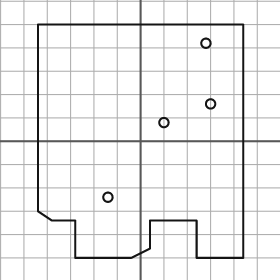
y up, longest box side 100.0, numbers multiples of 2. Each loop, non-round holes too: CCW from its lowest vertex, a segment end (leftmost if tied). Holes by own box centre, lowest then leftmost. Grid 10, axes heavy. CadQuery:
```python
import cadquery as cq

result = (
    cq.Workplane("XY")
    .moveTo(-28.0, -50.0)
    .lineTo(-4.0, -50.0)
    .lineTo(4.0, -46.0)
    .lineTo(4.0, -34.0)
    .lineTo(24.0, -34.0)
    .lineTo(24.0, -50.0)
    .lineTo(44.0, -50.0)
    .lineTo(44.0, 50.0)
    .lineTo(-44.0, 50.0)
    .lineTo(-44.0, -30.0)
    .lineTo(-38.0, -34.0)
    .lineTo(-28.0, -34.0)
    .close()
    .moveTo(-14.0, -24.0)
    .circle(2.0)
    .moveTo(10.0, 8.0)
    .circle(2.0)
    .moveTo(30.0, 16.0)
    .circle(2.0)
    .moveTo(28.0, 42.0)
    .circle(2.0)
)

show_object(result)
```